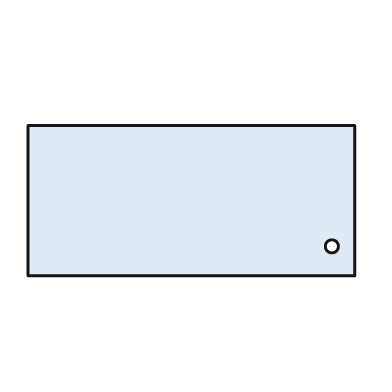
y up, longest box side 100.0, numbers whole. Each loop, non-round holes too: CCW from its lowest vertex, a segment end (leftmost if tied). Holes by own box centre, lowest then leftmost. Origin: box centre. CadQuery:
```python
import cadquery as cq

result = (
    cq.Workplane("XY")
    .moveTo(-50.0, -23.0)
    .lineTo(50.0, -23.0)
    .lineTo(50.0, 23.0)
    .lineTo(-50.0, 23.0)
    .close()
    .moveTo(43.0, -14.0)
    .circle(2.0)
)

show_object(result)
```